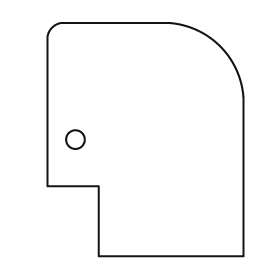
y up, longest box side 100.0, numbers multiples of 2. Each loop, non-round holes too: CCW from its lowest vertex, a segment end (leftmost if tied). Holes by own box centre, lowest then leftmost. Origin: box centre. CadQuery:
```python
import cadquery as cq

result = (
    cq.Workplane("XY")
    .moveTo(-20.0, -50.0)
    .lineTo(42.0, -50.0)
    .lineTo(42.0, 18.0)
    .threePointArc((32.0, 40.0), (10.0, 50.0))
    .lineTo(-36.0, 50.0)
    .threePointArc((-40.0, 48.0), (-42.0, 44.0))
    .lineTo(-42.0, -20.0)
    .lineTo(-20.0, -20.0)
    .close()
    .moveTo(-30.0, 0.0)
    .circle(4.0)
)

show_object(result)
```